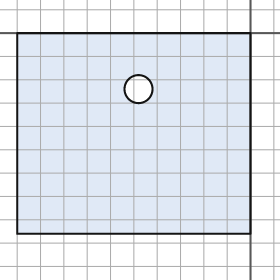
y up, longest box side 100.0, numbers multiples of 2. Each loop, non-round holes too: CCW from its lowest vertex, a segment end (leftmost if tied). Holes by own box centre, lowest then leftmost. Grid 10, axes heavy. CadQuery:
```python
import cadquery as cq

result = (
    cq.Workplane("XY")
    .moveTo(-100.0, -86.0)
    .lineTo(0.0, -86.0)
    .lineTo(0.0, 0.0)
    .lineTo(-100.0, 0.0)
    .close()
    .moveTo(-48.0, -24.0)
    .circle(6.0)
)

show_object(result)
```